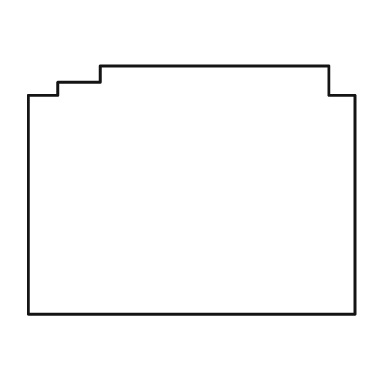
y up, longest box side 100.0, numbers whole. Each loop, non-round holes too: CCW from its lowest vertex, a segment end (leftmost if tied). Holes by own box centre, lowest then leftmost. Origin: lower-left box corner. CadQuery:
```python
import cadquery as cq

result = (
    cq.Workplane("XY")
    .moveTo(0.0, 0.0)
    .lineTo(100.0, 0.0)
    .lineTo(100.0, 67.0)
    .lineTo(92.0, 67.0)
    .lineTo(92.0, 76.0)
    .lineTo(22.0, 76.0)
    .lineTo(22.0, 71.0)
    .lineTo(9.0, 71.0)
    .lineTo(9.0, 67.0)
    .lineTo(0.0, 67.0)
    .close()
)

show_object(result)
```